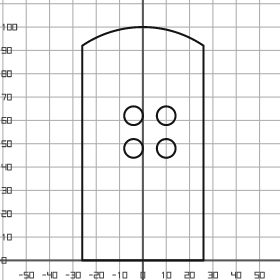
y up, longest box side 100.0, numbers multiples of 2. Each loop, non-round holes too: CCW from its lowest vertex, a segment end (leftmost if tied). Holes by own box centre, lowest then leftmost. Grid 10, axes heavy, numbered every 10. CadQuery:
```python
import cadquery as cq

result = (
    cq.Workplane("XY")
    .moveTo(-26.0, 0.0)
    .lineTo(26.0, 0.0)
    .lineTo(26.0, 92.0)
    .threePointArc((0.0, 100.0), (-26.0, 92.0))
    .close()
    .moveTo(-4.0, 48.0)
    .circle(4.0)
    .moveTo(10.0, 48.0)
    .circle(4.0)
    .moveTo(-4.0, 62.0)
    .circle(4.0)
    .moveTo(10.0, 62.0)
    .circle(4.0)
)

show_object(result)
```